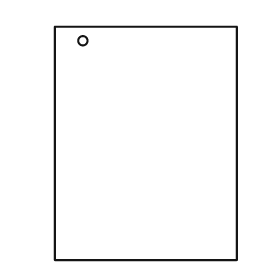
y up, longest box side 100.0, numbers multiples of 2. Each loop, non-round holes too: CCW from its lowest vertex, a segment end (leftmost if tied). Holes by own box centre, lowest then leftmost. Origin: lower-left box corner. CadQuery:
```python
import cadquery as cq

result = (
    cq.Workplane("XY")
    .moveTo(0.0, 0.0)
    .lineTo(78.0, 0.0)
    .lineTo(78.0, 100.0)
    .lineTo(0.0, 100.0)
    .close()
    .moveTo(12.0, 94.0)
    .circle(2.0)
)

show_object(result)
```